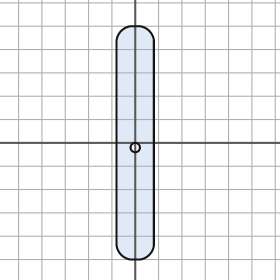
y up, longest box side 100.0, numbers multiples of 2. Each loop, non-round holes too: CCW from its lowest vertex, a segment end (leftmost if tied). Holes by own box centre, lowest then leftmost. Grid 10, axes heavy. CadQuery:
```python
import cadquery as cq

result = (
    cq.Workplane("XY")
    .moveTo(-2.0, -50.0)
    .lineTo(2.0, -50.0)
    .threePointArc((6.0, -48.0), (8.0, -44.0))
    .lineTo(8.0, 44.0)
    .threePointArc((6.0, 48.0), (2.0, 50.0))
    .lineTo(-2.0, 50.0)
    .threePointArc((-6.0, 48.0), (-8.0, 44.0))
    .lineTo(-8.0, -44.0)
    .threePointArc((-6.0, -48.0), (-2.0, -50.0))
    .close()
    .moveTo(0.0, -2.0)
    .circle(2.0)
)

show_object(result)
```